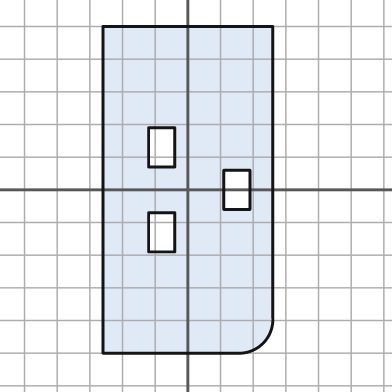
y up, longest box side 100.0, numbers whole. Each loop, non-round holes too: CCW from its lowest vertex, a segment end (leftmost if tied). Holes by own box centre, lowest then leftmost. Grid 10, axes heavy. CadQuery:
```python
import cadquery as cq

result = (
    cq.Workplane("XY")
    .moveTo(-26.0, -50.0)
    .lineTo(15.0, -50.0)
    .threePointArc((23.0, -47.0), (26.0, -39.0))
    .lineTo(26.0, 50.0)
    .lineTo(-26.0, 50.0)
    .close()
    .moveTo(-12.0, -19.0)
    .lineTo(-4.0, -19.0)
    .lineTo(-4.0, -7.0)
    .lineTo(-12.0, -7.0)
    .close()
    .moveTo(11.0, -6.0)
    .lineTo(19.0, -6.0)
    .lineTo(19.0, 6.0)
    .lineTo(11.0, 6.0)
    .close()
    .moveTo(-12.0, 7.0)
    .lineTo(-4.0, 7.0)
    .lineTo(-4.0, 19.0)
    .lineTo(-12.0, 19.0)
    .close()
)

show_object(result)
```